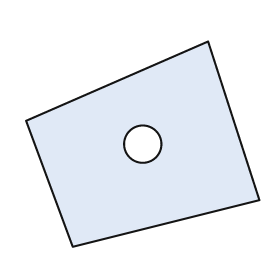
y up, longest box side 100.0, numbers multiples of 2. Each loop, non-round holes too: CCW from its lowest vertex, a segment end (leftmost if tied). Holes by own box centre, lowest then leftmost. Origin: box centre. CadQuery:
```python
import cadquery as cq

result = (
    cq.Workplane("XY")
    .moveTo(-30.0, -44.0)
    .lineTo(50.0, -24.0)
    .lineTo(28.0, 44.0)
    .lineTo(-50.0, 10.0)
    .close()
    .moveTo(0.0, 0.0)
    .circle(8.0)
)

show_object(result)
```